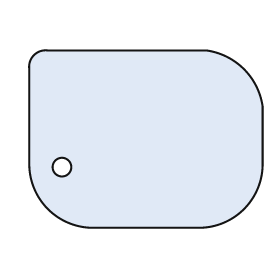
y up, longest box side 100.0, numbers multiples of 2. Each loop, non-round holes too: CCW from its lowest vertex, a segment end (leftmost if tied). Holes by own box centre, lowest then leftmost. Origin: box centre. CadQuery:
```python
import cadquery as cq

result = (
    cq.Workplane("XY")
    .moveTo(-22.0, -38.0)
    .lineTo(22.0, -38.0)
    .threePointArc((42.0, -30.0), (50.0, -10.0))
    .lineTo(50.0, 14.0)
    .threePointArc((42.0, 30.0), (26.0, 38.0))
    .lineTo(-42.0, 38.0)
    .threePointArc((-48.0, 36.0), (-50.0, 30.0))
    .lineTo(-50.0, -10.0)
    .threePointArc((-42.0, -30.0), (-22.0, -38.0))
    .close()
    .moveTo(-36.0, -12.0)
    .circle(4.0)
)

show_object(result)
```